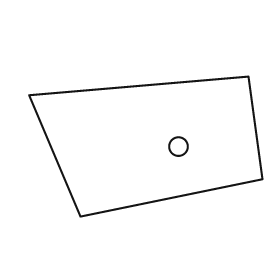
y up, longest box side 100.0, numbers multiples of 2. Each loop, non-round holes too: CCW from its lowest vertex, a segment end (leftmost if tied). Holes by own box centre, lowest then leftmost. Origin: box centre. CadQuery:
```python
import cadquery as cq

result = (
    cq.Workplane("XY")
    .moveTo(-28.0, -30.0)
    .lineTo(50.0, -14.0)
    .lineTo(44.0, 30.0)
    .lineTo(-50.0, 22.0)
    .close()
    .moveTo(14.0, 0.0)
    .circle(4.0)
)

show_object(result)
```